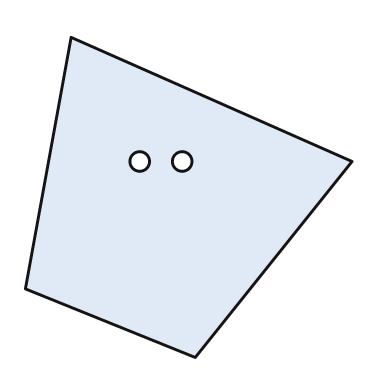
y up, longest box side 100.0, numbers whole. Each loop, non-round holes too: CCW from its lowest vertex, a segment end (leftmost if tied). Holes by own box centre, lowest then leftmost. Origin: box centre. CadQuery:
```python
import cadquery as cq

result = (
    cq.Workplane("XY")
    .moveTo(2.0, -49.0)
    .lineTo(50.0, 11.0)
    .lineTo(-36.0, 49.0)
    .lineTo(-50.0, -28.0)
    .close()
    .moveTo(-15.0, 11.0)
    .circle(3.0)
    .moveTo(-2.0, 11.0)
    .circle(3.0)
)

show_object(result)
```